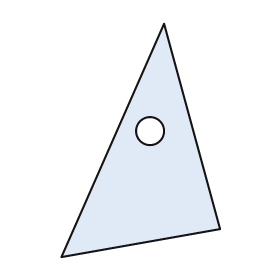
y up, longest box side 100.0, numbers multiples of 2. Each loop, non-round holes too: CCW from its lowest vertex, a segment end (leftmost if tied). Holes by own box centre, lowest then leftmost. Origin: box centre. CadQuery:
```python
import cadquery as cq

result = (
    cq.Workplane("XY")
    .moveTo(-34.0, -50.0)
    .lineTo(34.0, -38.0)
    .lineTo(10.0, 50.0)
    .close()
    .moveTo(4.0, 4.0)
    .circle(6.0)
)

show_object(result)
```